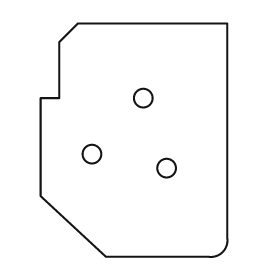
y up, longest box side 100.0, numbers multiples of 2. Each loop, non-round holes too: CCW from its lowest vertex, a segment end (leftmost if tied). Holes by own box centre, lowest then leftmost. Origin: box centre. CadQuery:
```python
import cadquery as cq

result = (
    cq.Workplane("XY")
    .moveTo(-12.0, -50.0)
    .lineTo(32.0, -50.0)
    .threePointArc((38.0, -48.0), (40.0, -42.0))
    .lineTo(40.0, 50.0)
    .lineTo(-24.0, 50.0)
    .lineTo(-32.0, 42.0)
    .lineTo(-32.0, 18.0)
    .lineTo(-40.0, 18.0)
    .lineTo(-40.0, -24.0)
    .close()
    .moveTo(14.0, -12.0)
    .circle(4.0)
    .moveTo(-18.0, -6.0)
    .circle(4.0)
    .moveTo(4.0, 18.0)
    .circle(4.0)
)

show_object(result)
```